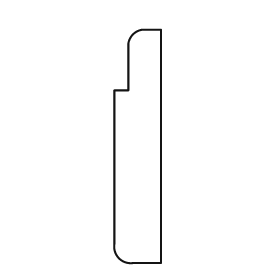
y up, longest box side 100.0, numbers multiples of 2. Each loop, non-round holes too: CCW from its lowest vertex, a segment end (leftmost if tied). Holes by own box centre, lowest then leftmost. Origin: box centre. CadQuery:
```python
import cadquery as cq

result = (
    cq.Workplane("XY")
    .moveTo(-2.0, -50.0)
    .lineTo(10.0, -50.0)
    .lineTo(10.0, 50.0)
    .lineTo(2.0, 50.0)
    .threePointArc((-2.0, 48.0), (-4.0, 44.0))
    .lineTo(-4.0, 24.0)
    .lineTo(-10.0, 24.0)
    .lineTo(-10.0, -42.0)
    .threePointArc((-8.0, -48.0), (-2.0, -50.0))
    .close()
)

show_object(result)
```